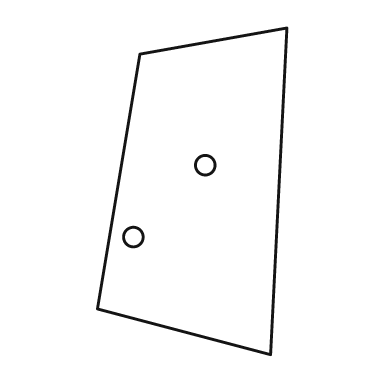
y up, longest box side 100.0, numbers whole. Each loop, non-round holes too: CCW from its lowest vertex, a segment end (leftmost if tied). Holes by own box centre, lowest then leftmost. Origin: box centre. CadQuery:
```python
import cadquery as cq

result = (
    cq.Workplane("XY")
    .moveTo(24.0, -50.0)
    .lineTo(29.0, 50.0)
    .lineTo(-16.0, 42.0)
    .lineTo(-29.0, -36.0)
    .close()
    .moveTo(-18.0, -14.0)
    .circle(3.0)
    .moveTo(4.0, 8.0)
    .circle(3.0)
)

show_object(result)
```